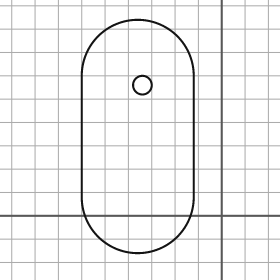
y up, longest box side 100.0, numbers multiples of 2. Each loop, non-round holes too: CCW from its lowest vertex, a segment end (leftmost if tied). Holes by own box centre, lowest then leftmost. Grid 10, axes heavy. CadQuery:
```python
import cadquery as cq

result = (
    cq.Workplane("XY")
    .moveTo(-60.0, 8.0)
    .threePointArc((-36.0, -16.0), (-12.0, 8.0))
    .lineTo(-12.0, 60.0)
    .threePointArc((-36.0, 84.0), (-60.0, 60.0))
    .close()
    .moveTo(-34.0, 56.0)
    .circle(4.0)
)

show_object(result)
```